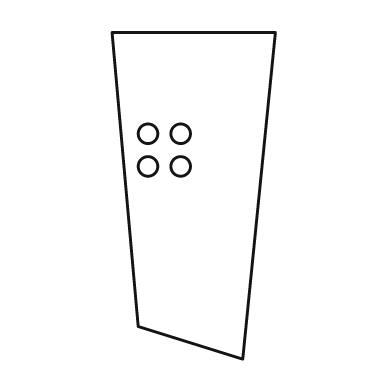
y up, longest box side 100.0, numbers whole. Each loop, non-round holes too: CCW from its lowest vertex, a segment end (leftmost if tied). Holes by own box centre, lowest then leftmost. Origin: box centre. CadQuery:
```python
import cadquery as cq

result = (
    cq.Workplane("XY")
    .moveTo(15.0, -50.0)
    .lineTo(25.0, 50.0)
    .lineTo(-25.0, 50.0)
    .lineTo(-17.0, -40.0)
    .close()
    .moveTo(-14.0, 9.0)
    .circle(3.0)
    .moveTo(-4.0, 9.0)
    .circle(3.0)
    .moveTo(-14.0, 19.0)
    .circle(3.0)
    .moveTo(-4.0, 19.0)
    .circle(3.0)
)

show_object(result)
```